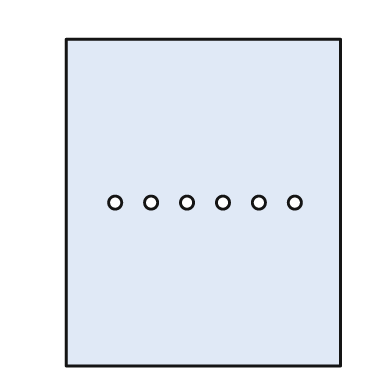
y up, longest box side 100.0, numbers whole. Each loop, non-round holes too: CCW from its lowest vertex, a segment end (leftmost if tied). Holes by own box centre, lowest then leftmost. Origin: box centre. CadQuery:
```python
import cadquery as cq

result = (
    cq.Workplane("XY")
    .moveTo(-42.0, -50.0)
    .lineTo(42.0, -50.0)
    .lineTo(42.0, 50.0)
    .lineTo(-42.0, 50.0)
    .close()
    .moveTo(-27.0, 0.0)
    .circle(2.0)
    .moveTo(-16.0, 0.0)
    .circle(2.0)
    .moveTo(-5.0, 0.0)
    .circle(2.0)
    .moveTo(6.0, 0.0)
    .circle(2.0)
    .moveTo(17.0, 0.0)
    .circle(2.0)
    .moveTo(28.0, 0.0)
    .circle(2.0)
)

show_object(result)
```